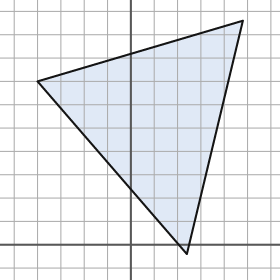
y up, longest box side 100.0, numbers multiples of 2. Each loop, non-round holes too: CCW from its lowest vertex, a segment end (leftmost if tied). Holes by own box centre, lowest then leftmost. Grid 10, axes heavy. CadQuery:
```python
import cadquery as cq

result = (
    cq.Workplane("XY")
    .moveTo(24.0, -4.0)
    .lineTo(48.0, 96.0)
    .lineTo(-40.0, 70.0)
    .close()
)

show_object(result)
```